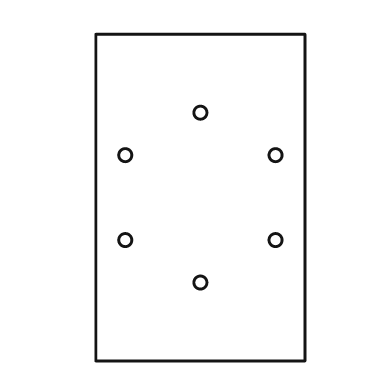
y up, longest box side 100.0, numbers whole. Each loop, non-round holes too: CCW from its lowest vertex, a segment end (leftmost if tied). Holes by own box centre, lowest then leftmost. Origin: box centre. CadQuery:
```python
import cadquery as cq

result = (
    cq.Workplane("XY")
    .moveTo(-32.0, -50.0)
    .lineTo(32.0, -50.0)
    .lineTo(32.0, 50.0)
    .lineTo(-32.0, 50.0)
    .close()
    .moveTo(0.0, -26.0)
    .circle(2.0)
    .moveTo(-23.0, -13.0)
    .circle(2.0)
    .moveTo(23.0, -13.0)
    .circle(2.0)
    .moveTo(-23.0, 13.0)
    .circle(2.0)
    .moveTo(23.0, 13.0)
    .circle(2.0)
    .moveTo(0.0, 26.0)
    .circle(2.0)
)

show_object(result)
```